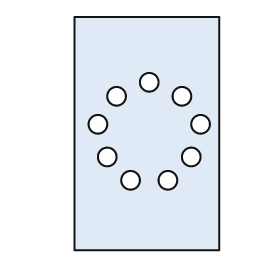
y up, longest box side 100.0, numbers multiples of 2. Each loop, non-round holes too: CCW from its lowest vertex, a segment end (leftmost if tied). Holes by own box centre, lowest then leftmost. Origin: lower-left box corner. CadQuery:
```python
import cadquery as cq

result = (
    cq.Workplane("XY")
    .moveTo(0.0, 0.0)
    .lineTo(62.0, 0.0)
    .lineTo(62.0, 100.0)
    .lineTo(0.0, 100.0)
    .close()
    .moveTo(24.0, 30.0)
    .circle(4.0)
    .moveTo(40.0, 30.0)
    .circle(4.0)
    .moveTo(14.0, 40.0)
    .circle(4.0)
    .moveTo(50.0, 40.0)
    .circle(4.0)
    .moveTo(10.0, 54.0)
    .circle(4.0)
    .moveTo(54.0, 54.0)
    .circle(4.0)
    .moveTo(18.0, 66.0)
    .circle(4.0)
    .moveTo(46.0, 66.0)
    .circle(4.0)
    .moveTo(32.0, 72.0)
    .circle(4.0)
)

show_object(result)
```